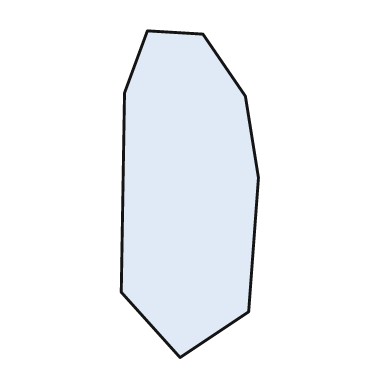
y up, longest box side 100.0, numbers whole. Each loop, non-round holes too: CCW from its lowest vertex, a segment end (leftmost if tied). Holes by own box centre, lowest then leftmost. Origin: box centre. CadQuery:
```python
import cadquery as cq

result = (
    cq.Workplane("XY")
    .moveTo(-3.0, -50.0)
    .lineTo(18.0, -36.0)
    .lineTo(21.0, 5.0)
    .lineTo(17.0, 30.0)
    .lineTo(4.0, 49.0)
    .lineTo(-13.0, 50.0)
    .lineTo(-20.0, 31.0)
    .lineTo(-21.0, -30.0)
    .close()
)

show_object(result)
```